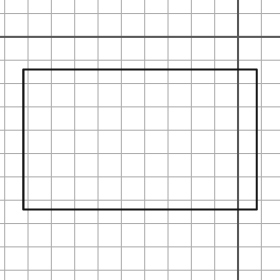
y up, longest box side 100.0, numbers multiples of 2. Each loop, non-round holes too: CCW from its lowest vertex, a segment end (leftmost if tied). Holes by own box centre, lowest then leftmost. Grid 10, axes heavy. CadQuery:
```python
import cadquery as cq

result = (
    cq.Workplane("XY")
    .moveTo(-92.0, -74.0)
    .lineTo(8.0, -74.0)
    .lineTo(8.0, -14.0)
    .lineTo(-92.0, -14.0)
    .close()
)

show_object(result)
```